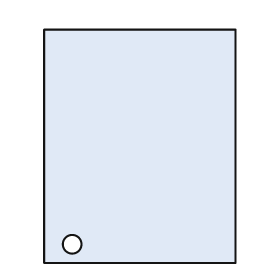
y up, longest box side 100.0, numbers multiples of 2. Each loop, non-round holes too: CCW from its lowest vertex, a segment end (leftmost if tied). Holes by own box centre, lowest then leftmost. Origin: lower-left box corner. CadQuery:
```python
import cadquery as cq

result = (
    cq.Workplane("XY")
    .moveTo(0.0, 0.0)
    .lineTo(82.0, 0.0)
    .lineTo(82.0, 100.0)
    .lineTo(0.0, 100.0)
    .close()
    .moveTo(12.0, 8.0)
    .circle(4.0)
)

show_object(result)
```